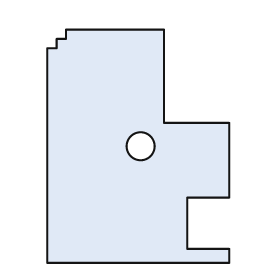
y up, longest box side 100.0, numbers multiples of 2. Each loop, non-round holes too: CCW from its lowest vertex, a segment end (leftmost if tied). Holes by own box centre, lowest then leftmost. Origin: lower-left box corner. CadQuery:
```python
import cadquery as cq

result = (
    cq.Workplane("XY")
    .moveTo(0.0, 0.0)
    .lineTo(78.0, 0.0)
    .lineTo(78.0, 6.0)
    .lineTo(60.0, 6.0)
    .lineTo(60.0, 28.0)
    .lineTo(78.0, 28.0)
    .lineTo(78.0, 60.0)
    .lineTo(50.0, 60.0)
    .lineTo(50.0, 100.0)
    .lineTo(8.0, 100.0)
    .lineTo(8.0, 96.0)
    .lineTo(4.0, 96.0)
    .lineTo(4.0, 92.0)
    .lineTo(0.0, 92.0)
    .close()
    .moveTo(40.0, 50.0)
    .circle(6.0)
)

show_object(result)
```